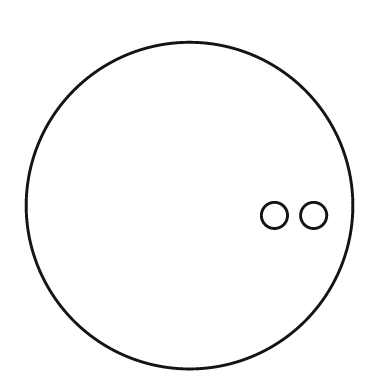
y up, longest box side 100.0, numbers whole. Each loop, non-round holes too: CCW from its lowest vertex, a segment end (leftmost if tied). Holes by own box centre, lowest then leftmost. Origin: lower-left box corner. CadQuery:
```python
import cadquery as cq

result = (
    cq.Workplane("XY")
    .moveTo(50.0, 50.0)
    .circle(50.0)
    .moveTo(76.0, 47.0)
    .circle(4.0)
    .moveTo(88.0, 47.0)
    .circle(4.0)
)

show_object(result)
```